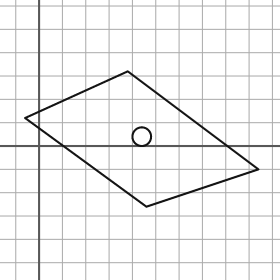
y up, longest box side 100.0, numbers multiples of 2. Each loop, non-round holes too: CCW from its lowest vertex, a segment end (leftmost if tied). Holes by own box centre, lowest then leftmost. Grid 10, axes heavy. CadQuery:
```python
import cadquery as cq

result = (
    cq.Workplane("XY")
    .moveTo(46.0, -26.0)
    .lineTo(94.0, -10.0)
    .lineTo(38.0, 32.0)
    .lineTo(-6.0, 12.0)
    .close()
    .moveTo(44.0, 4.0)
    .circle(4.0)
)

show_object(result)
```